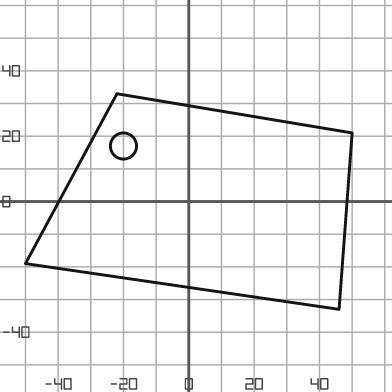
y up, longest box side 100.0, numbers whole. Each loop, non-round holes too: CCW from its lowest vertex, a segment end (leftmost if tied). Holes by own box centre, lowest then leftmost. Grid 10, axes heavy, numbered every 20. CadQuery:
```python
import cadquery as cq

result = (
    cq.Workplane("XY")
    .moveTo(46.0, -33.0)
    .lineTo(50.0, 21.0)
    .lineTo(-22.0, 33.0)
    .lineTo(-50.0, -19.0)
    .close()
    .moveTo(-20.0, 17.0)
    .circle(4.0)
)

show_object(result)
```